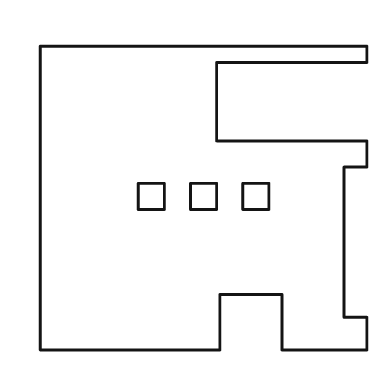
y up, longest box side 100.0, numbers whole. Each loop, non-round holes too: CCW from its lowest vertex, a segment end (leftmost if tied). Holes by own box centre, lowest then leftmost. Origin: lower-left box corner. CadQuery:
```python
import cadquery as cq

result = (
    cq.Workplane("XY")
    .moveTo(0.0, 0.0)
    .lineTo(55.0, 0.0)
    .lineTo(55.0, 17.0)
    .lineTo(74.0, 17.0)
    .lineTo(74.0, 0.0)
    .lineTo(100.0, 0.0)
    .lineTo(100.0, 10.0)
    .lineTo(93.0, 10.0)
    .lineTo(93.0, 56.0)
    .lineTo(100.0, 56.0)
    .lineTo(100.0, 64.0)
    .lineTo(54.0, 64.0)
    .lineTo(54.0, 88.0)
    .lineTo(100.0, 88.0)
    .lineTo(100.0, 93.0)
    .lineTo(0.0, 93.0)
    .close()
    .moveTo(30.0, 43.0)
    .lineTo(38.0, 43.0)
    .lineTo(38.0, 51.0)
    .lineTo(30.0, 51.0)
    .close()
    .moveTo(46.0, 43.0)
    .lineTo(54.0, 43.0)
    .lineTo(54.0, 51.0)
    .lineTo(46.0, 51.0)
    .close()
    .moveTo(62.0, 43.0)
    .lineTo(70.0, 43.0)
    .lineTo(70.0, 51.0)
    .lineTo(62.0, 51.0)
    .close()
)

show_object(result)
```